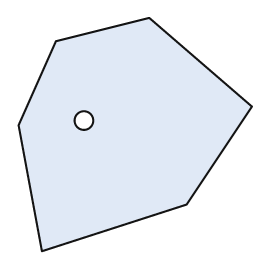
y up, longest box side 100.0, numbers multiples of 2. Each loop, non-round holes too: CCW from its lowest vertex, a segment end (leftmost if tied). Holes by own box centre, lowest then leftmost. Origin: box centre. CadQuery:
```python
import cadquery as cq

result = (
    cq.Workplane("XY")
    .moveTo(-40.0, -50.0)
    .lineTo(22.0, -30.0)
    .lineTo(50.0, 12.0)
    .lineTo(6.0, 50.0)
    .lineTo(-34.0, 40.0)
    .lineTo(-50.0, 4.0)
    .close()
    .moveTo(-22.0, 6.0)
    .circle(4.0)
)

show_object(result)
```